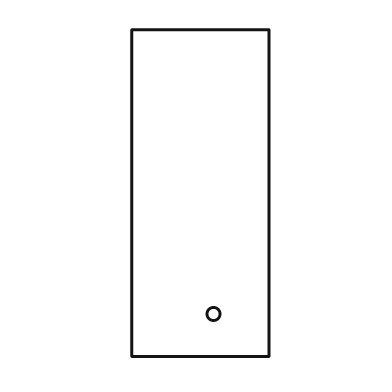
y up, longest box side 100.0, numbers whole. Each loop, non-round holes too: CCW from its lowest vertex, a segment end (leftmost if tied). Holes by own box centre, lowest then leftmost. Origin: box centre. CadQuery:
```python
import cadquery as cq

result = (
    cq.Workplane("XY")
    .moveTo(-21.0, -50.0)
    .lineTo(21.0, -50.0)
    .lineTo(21.0, 50.0)
    .lineTo(-21.0, 50.0)
    .close()
    .moveTo(4.0, -37.0)
    .circle(2.0)
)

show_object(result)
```